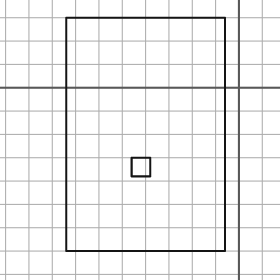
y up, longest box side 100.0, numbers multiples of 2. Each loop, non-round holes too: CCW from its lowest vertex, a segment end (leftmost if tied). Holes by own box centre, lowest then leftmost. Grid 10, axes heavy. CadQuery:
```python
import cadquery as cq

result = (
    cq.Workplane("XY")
    .moveTo(-74.0, -70.0)
    .lineTo(-6.0, -70.0)
    .lineTo(-6.0, 30.0)
    .lineTo(-74.0, 30.0)
    .close()
    .moveTo(-46.0, -38.0)
    .lineTo(-38.0, -38.0)
    .lineTo(-38.0, -30.0)
    .lineTo(-46.0, -30.0)
    .close()
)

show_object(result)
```